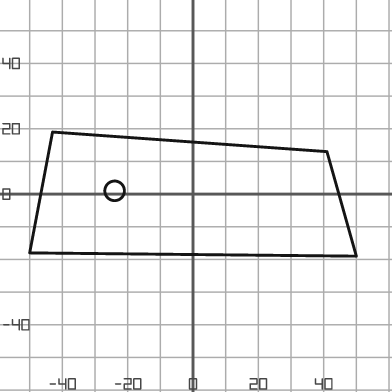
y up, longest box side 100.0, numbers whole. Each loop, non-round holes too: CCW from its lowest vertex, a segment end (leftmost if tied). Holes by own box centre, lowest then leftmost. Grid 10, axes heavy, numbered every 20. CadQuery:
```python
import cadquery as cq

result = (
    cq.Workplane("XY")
    .moveTo(50.0, -19.0)
    .lineTo(41.0, 13.0)
    .lineTo(-43.0, 19.0)
    .lineTo(-50.0, -18.0)
    .close()
    .moveTo(-24.0, 1.0)
    .circle(3.0)
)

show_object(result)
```